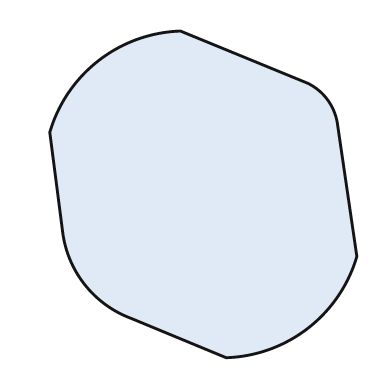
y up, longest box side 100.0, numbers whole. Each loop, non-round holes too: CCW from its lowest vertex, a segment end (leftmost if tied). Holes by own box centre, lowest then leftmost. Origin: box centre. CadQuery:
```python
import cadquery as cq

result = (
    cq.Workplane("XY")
    .moveTo(7.0, -50.0)
    .threePointArc((32.0, -41.0), (47.0, -19.0))
    .lineTo(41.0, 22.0)
    .threePointArc((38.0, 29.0), (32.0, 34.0))
    .lineTo(-7.0, 50.0)
    .threePointArc((-32.0, 41.0), (-47.0, 19.0))
    .lineTo(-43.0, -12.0)
    .threePointArc((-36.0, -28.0), (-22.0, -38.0))
    .close()
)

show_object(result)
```